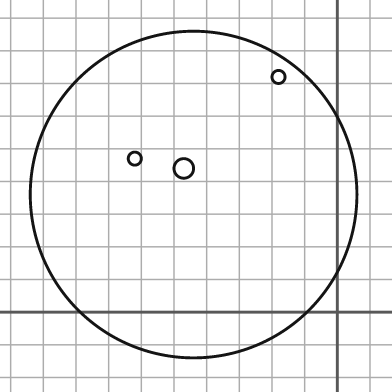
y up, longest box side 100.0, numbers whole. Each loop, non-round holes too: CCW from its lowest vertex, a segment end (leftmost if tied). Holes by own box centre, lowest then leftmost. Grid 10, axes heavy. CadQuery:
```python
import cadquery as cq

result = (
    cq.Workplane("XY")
    .moveTo(-44.0, 36.0)
    .circle(50.0)
    .moveTo(-47.0, 44.0)
    .circle(3.0)
    .moveTo(-62.0, 47.0)
    .circle(2.0)
    .moveTo(-18.0, 72.0)
    .circle(2.0)
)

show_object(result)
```